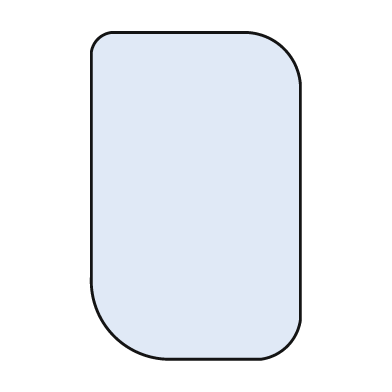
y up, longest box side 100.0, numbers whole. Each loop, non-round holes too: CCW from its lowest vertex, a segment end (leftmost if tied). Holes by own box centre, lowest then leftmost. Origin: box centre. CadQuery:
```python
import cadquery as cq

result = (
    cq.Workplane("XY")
    .moveTo(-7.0, -50.0)
    .lineTo(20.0, -50.0)
    .threePointArc((28.0, -46.0), (32.0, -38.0))
    .lineTo(32.0, 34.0)
    .threePointArc((27.0, 45.0), (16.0, 50.0))
    .lineTo(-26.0, 50.0)
    .threePointArc((-30.0, 48.0), (-32.0, 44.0))
    .lineTo(-32.0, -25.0)
    .threePointArc((-25.0, -43.0), (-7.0, -50.0))
    .close()
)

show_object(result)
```